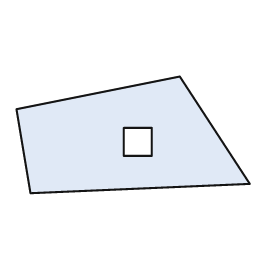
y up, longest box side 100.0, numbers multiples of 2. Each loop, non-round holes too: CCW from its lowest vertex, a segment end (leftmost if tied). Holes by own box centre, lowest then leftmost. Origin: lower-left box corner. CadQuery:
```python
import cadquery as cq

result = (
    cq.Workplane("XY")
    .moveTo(6.0, 0.0)
    .lineTo(100.0, 4.0)
    .lineTo(70.0, 50.0)
    .lineTo(0.0, 36.0)
    .close()
    .moveTo(46.0, 16.0)
    .lineTo(58.0, 16.0)
    .lineTo(58.0, 28.0)
    .lineTo(46.0, 28.0)
    .close()
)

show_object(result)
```